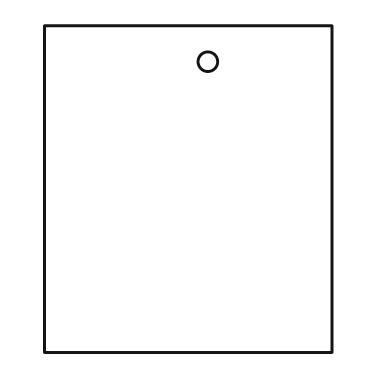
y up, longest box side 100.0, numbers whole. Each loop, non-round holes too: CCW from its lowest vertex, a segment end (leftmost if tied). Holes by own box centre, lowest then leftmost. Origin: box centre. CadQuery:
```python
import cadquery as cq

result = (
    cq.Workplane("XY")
    .moveTo(-44.0, -50.0)
    .lineTo(44.0, -50.0)
    .lineTo(44.0, 50.0)
    .lineTo(-44.0, 50.0)
    .close()
    .moveTo(6.0, 39.0)
    .circle(3.0)
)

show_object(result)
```